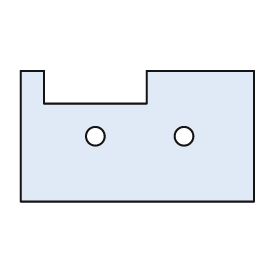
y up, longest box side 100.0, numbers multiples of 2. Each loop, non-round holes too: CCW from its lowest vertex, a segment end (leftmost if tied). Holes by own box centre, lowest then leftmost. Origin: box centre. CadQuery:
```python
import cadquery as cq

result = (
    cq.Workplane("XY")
    .moveTo(-50.0, -28.0)
    .lineTo(50.0, -28.0)
    .lineTo(50.0, 28.0)
    .lineTo(4.0, 28.0)
    .lineTo(4.0, 14.0)
    .lineTo(-40.0, 14.0)
    .lineTo(-40.0, 28.0)
    .lineTo(-50.0, 28.0)
    .close()
    .moveTo(-18.0, 0.0)
    .circle(4.0)
    .moveTo(20.0, 0.0)
    .circle(4.0)
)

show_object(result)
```